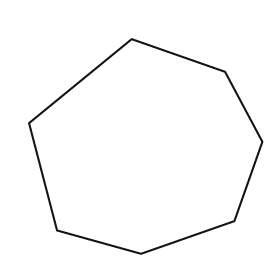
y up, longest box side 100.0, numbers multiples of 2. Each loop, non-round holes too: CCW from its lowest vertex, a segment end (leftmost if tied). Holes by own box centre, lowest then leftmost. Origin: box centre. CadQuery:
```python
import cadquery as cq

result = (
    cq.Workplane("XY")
    .moveTo(-2.0, -46.0)
    .lineTo(38.0, -32.0)
    .lineTo(50.0, 2.0)
    .lineTo(34.0, 32.0)
    .lineTo(-6.0, 46.0)
    .lineTo(-50.0, 10.0)
    .lineTo(-38.0, -36.0)
    .close()
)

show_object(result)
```